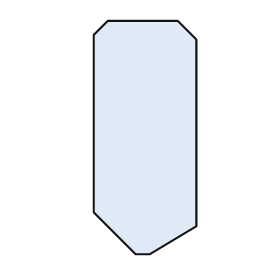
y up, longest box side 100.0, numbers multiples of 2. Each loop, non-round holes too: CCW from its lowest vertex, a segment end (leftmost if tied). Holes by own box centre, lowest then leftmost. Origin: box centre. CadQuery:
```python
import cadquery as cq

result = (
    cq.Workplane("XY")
    .moveTo(-4.0, -50.0)
    .lineTo(2.0, -50.0)
    .lineTo(22.0, -38.0)
    .lineTo(22.0, 42.0)
    .lineTo(14.0, 50.0)
    .lineTo(-16.0, 50.0)
    .lineTo(-22.0, 44.0)
    .lineTo(-22.0, -32.0)
    .close()
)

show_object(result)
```